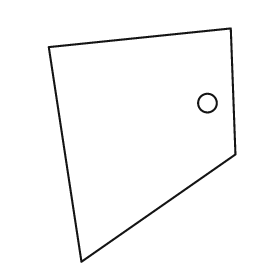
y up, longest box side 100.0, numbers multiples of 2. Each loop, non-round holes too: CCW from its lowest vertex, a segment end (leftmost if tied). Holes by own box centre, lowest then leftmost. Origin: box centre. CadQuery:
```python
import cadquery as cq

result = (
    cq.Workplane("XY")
    .moveTo(-26.0, -50.0)
    .lineTo(40.0, -4.0)
    .lineTo(38.0, 50.0)
    .lineTo(-40.0, 42.0)
    .close()
    .moveTo(28.0, 18.0)
    .circle(4.0)
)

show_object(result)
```